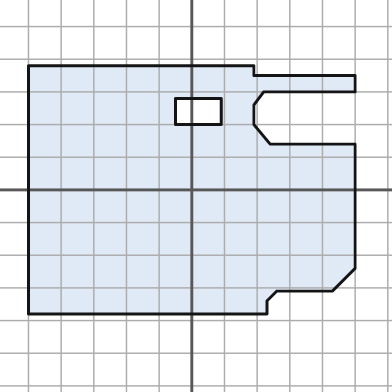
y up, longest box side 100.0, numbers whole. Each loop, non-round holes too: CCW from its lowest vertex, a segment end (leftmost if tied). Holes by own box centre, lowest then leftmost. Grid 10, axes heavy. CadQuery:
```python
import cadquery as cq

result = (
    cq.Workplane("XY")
    .moveTo(-50.0, -38.0)
    .lineTo(23.0, -38.0)
    .lineTo(23.0, -34.0)
    .lineTo(26.0, -31.0)
    .lineTo(43.0, -31.0)
    .lineTo(50.0, -24.0)
    .lineTo(50.0, 14.0)
    .lineTo(24.0, 14.0)
    .lineTo(19.0, 20.0)
    .lineTo(19.0, 26.0)
    .lineTo(22.0, 30.0)
    .lineTo(50.0, 30.0)
    .lineTo(50.0, 35.0)
    .lineTo(19.0, 35.0)
    .lineTo(19.0, 38.0)
    .lineTo(-50.0, 38.0)
    .close()
    .moveTo(-5.0, 20.0)
    .lineTo(9.0, 20.0)
    .lineTo(9.0, 28.0)
    .lineTo(-5.0, 28.0)
    .close()
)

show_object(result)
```